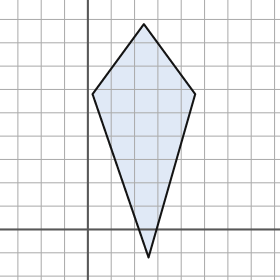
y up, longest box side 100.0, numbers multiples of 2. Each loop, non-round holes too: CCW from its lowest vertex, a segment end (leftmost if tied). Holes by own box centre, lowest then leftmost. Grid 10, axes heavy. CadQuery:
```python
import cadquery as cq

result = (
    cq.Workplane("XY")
    .moveTo(26.0, -12.0)
    .lineTo(46.0, 58.0)
    .lineTo(24.0, 88.0)
    .lineTo(2.0, 58.0)
    .close()
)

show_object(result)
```